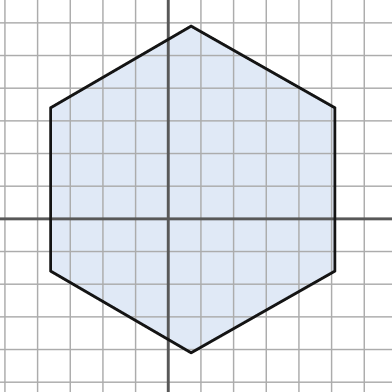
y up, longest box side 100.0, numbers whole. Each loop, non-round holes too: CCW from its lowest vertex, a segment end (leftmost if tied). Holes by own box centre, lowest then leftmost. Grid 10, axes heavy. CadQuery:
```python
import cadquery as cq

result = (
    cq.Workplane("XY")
    .moveTo(7.0, -41.0)
    .lineTo(51.0, -16.0)
    .lineTo(51.0, 34.0)
    .lineTo(7.0, 59.0)
    .lineTo(-36.0, 34.0)
    .lineTo(-36.0, -16.0)
    .close()
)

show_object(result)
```